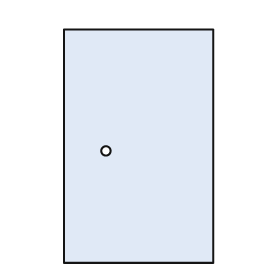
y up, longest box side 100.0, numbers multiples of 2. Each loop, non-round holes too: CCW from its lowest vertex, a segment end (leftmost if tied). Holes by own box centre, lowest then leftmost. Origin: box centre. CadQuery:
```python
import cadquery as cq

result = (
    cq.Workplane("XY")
    .moveTo(-32.0, -50.0)
    .lineTo(32.0, -50.0)
    .lineTo(32.0, 50.0)
    .lineTo(-32.0, 50.0)
    .close()
    .moveTo(-14.0, -2.0)
    .circle(2.0)
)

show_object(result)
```